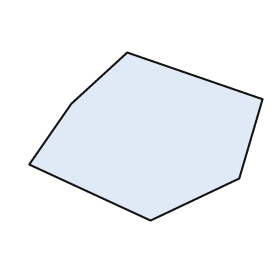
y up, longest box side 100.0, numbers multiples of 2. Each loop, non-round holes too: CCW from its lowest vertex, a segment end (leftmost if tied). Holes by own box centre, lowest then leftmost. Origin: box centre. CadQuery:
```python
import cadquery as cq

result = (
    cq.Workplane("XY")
    .moveTo(2.0, -36.0)
    .lineTo(40.0, -18.0)
    .lineTo(50.0, 16.0)
    .lineTo(-8.0, 36.0)
    .lineTo(-32.0, 14.0)
    .lineTo(-50.0, -12.0)
    .close()
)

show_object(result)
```